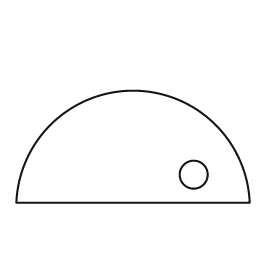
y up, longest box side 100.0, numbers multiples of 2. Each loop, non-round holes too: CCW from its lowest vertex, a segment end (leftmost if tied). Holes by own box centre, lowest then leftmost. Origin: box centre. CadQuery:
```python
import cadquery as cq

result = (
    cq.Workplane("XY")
    .moveTo(-50.0, -24.0)
    .lineTo(50.0, -24.0)
    .threePointArc((0.0, 24.0), (-50.0, -24.0))
    .close()
    .moveTo(26.0, -12.0)
    .circle(6.0)
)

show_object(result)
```